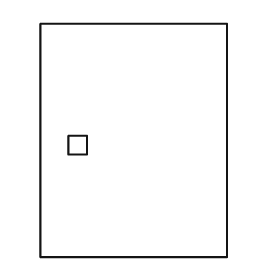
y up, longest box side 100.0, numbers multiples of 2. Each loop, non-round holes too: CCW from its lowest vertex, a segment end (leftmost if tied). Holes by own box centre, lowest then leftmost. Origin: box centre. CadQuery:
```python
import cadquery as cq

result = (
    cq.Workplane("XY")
    .moveTo(-40.0, -50.0)
    .lineTo(40.0, -50.0)
    .lineTo(40.0, 50.0)
    .lineTo(-40.0, 50.0)
    .close()
    .moveTo(-28.0, -6.0)
    .lineTo(-20.0, -6.0)
    .lineTo(-20.0, 2.0)
    .lineTo(-28.0, 2.0)
    .close()
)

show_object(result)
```